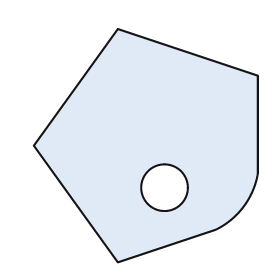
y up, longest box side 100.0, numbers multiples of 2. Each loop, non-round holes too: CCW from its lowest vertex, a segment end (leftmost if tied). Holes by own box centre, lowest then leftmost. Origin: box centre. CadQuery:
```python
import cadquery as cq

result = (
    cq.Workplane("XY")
    .moveTo(-12.0, -50.0)
    .lineTo(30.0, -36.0)
    .threePointArc((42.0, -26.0), (48.0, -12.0))
    .lineTo(48.0, 30.0)
    .lineTo(-12.0, 50.0)
    .lineTo(-48.0, 0.0)
    .close()
    .moveTo(8.0, -18.0)
    .circle(10.0)
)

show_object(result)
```